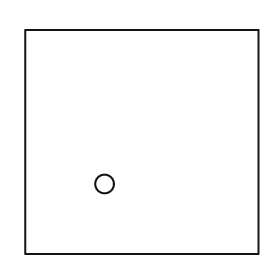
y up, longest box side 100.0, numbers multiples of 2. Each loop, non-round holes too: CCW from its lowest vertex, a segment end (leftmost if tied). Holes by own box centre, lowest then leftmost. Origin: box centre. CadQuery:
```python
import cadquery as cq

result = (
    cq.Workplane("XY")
    .moveTo(-50.0, -48.0)
    .lineTo(50.0, -48.0)
    .lineTo(50.0, 48.0)
    .lineTo(-50.0, 48.0)
    .close()
    .moveTo(-16.0, -18.0)
    .circle(4.0)
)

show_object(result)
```